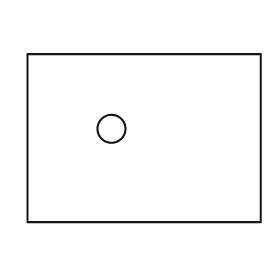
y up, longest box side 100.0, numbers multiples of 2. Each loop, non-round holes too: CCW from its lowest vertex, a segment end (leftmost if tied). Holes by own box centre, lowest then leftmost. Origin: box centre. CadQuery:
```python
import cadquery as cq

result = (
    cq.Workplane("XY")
    .moveTo(-50.0, -36.0)
    .lineTo(50.0, -36.0)
    .lineTo(50.0, 36.0)
    .lineTo(-50.0, 36.0)
    .close()
    .moveTo(-14.0, 4.0)
    .circle(6.0)
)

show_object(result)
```